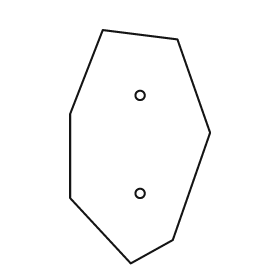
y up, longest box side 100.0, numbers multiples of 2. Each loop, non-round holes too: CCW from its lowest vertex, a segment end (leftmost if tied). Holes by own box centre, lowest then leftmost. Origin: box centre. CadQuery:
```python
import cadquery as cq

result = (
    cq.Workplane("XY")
    .moveTo(-4.0, -50.0)
    .lineTo(14.0, -40.0)
    .lineTo(30.0, 6.0)
    .lineTo(16.0, 46.0)
    .lineTo(-16.0, 50.0)
    .lineTo(-30.0, 14.0)
    .lineTo(-30.0, -22.0)
    .close()
    .moveTo(0.0, -20.0)
    .circle(2.0)
    .moveTo(0.0, 22.0)
    .circle(2.0)
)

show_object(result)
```